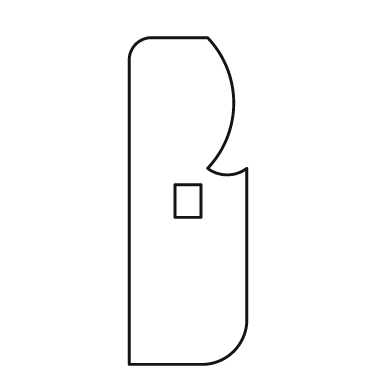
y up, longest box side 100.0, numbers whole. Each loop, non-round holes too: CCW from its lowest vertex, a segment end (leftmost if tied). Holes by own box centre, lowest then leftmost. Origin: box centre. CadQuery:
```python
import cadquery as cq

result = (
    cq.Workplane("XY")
    .moveTo(-18.0, -50.0)
    .lineTo(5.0, -50.0)
    .threePointArc((14.0, -46.0), (18.0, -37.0))
    .lineTo(18.0, 10.0)
    .threePointArc((12.0, 8.0), (6.0, 10.0))
    .threePointArc((14.0, 30.0), (6.0, 50.0))
    .lineTo(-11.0, 50.0)
    .threePointArc((-16.0, 48.0), (-18.0, 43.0))
    .close()
    .moveTo(-4.0, -5.0)
    .lineTo(4.0, -5.0)
    .lineTo(4.0, 5.0)
    .lineTo(-4.0, 5.0)
    .close()
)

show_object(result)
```